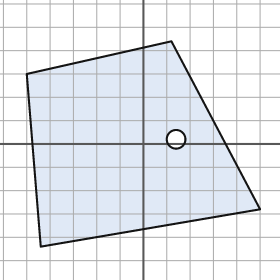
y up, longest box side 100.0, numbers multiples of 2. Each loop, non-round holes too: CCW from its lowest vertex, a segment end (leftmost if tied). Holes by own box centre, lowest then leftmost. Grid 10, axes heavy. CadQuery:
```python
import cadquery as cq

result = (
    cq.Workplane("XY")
    .moveTo(-44.0, -44.0)
    .lineTo(50.0, -28.0)
    .lineTo(12.0, 44.0)
    .lineTo(-50.0, 30.0)
    .close()
    .moveTo(14.0, 2.0)
    .circle(4.0)
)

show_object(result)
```